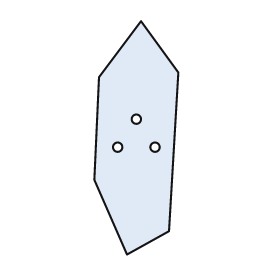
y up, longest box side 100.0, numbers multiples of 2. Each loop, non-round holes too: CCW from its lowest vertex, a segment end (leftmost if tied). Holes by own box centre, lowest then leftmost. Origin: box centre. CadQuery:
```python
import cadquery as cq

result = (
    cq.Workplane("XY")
    .moveTo(-4.0, -50.0)
    .lineTo(14.0, -40.0)
    .lineTo(18.0, 28.0)
    .lineTo(2.0, 50.0)
    .lineTo(-16.0, 26.0)
    .lineTo(-18.0, -18.0)
    .close()
    .moveTo(-8.0, -4.0)
    .circle(2.0)
    .moveTo(8.0, -4.0)
    .circle(2.0)
    .moveTo(0.0, 8.0)
    .circle(2.0)
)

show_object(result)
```